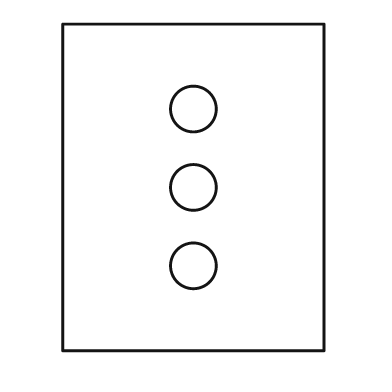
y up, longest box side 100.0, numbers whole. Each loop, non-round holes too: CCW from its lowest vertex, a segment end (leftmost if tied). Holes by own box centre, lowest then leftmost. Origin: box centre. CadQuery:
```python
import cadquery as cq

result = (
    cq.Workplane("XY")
    .moveTo(-40.0, -50.0)
    .lineTo(40.0, -50.0)
    .lineTo(40.0, 50.0)
    .lineTo(-40.0, 50.0)
    .close()
    .moveTo(0.0, -24.0)
    .circle(7.0)
    .moveTo(0.0, 0.0)
    .circle(7.0)
    .moveTo(0.0, 24.0)
    .circle(7.0)
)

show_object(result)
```